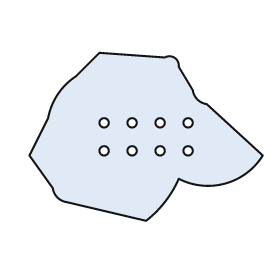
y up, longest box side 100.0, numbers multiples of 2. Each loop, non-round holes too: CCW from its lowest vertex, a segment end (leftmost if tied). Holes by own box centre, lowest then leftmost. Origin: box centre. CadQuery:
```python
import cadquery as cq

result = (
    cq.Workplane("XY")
    .moveTo(0.0, -36.0)
    .threePointArc((8.0, -28.0), (14.0, -18.0))
    .threePointArc((34.0, -20.0), (50.0, -8.0))
    .lineTo(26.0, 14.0)
    .threePointArc((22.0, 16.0), (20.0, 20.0))
    .lineTo(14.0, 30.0)
    .threePointArc((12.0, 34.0), (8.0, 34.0))
    .lineTo(-20.0, 36.0)
    .lineTo(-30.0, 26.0)
    .threePointArc((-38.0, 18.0), (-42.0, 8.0))
    .lineTo(-50.0, -8.0)
    .lineTo(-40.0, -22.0)
    .threePointArc((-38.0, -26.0), (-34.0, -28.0))
    .close()
    .moveTo(-18.0, -6.0)
    .circle(2.0)
    .moveTo(-6.0, -6.0)
    .circle(2.0)
    .moveTo(6.0, -6.0)
    .circle(2.0)
    .moveTo(18.0, -6.0)
    .circle(2.0)
    .moveTo(-18.0, 6.0)
    .circle(2.0)
    .moveTo(-6.0, 6.0)
    .circle(2.0)
    .moveTo(6.0, 6.0)
    .circle(2.0)
    .moveTo(18.0, 6.0)
    .circle(2.0)
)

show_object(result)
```